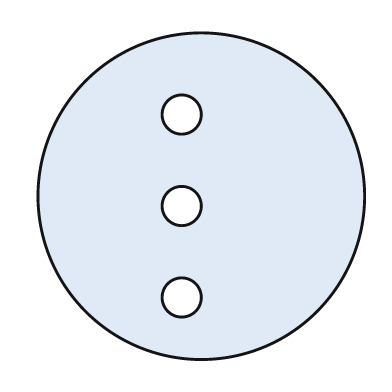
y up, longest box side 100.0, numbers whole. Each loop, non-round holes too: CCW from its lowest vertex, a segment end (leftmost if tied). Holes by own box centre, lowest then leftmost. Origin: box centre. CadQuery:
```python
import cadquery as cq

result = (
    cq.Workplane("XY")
    .moveTo(0.0, 0.0)
    .circle(50.0)
    .moveTo(-6.0, -31.0)
    .circle(6.0)
    .moveTo(-6.0, -3.0)
    .circle(6.0)
    .moveTo(-6.0, 25.0)
    .circle(6.0)
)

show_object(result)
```